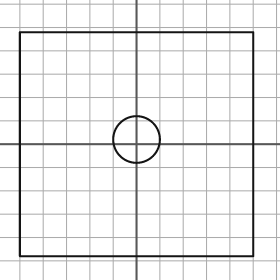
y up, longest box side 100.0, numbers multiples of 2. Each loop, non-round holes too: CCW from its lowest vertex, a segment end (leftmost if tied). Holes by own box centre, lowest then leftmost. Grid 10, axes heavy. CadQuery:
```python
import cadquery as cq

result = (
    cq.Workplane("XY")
    .moveTo(-50.0, -48.0)
    .lineTo(50.0, -48.0)
    .lineTo(50.0, 48.0)
    .lineTo(-50.0, 48.0)
    .close()
    .moveTo(0.0, 2.0)
    .circle(10.0)
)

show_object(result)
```